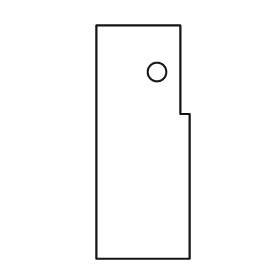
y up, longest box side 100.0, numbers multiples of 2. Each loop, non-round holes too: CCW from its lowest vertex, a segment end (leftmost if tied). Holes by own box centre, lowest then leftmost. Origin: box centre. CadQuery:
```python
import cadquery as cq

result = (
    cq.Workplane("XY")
    .moveTo(-20.0, -50.0)
    .lineTo(20.0, -50.0)
    .lineTo(20.0, 12.0)
    .lineTo(16.0, 12.0)
    .lineTo(16.0, 50.0)
    .lineTo(-20.0, 50.0)
    .close()
    .moveTo(6.0, 30.0)
    .circle(4.0)
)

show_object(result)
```